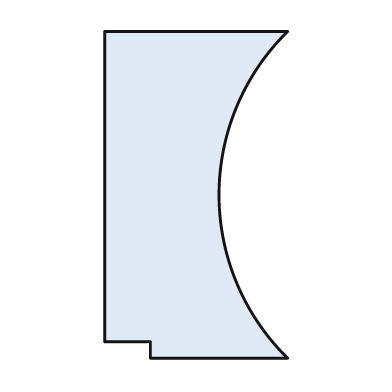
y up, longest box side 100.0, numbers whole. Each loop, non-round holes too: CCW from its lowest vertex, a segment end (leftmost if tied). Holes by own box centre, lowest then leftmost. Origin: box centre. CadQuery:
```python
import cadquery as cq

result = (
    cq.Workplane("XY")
    .moveTo(-14.0, -50.0)
    .lineTo(28.0, -50.0)
    .threePointArc((7.0, 0.0), (28.0, 50.0))
    .lineTo(-28.0, 50.0)
    .lineTo(-28.0, -45.0)
    .lineTo(-14.0, -45.0)
    .close()
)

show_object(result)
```